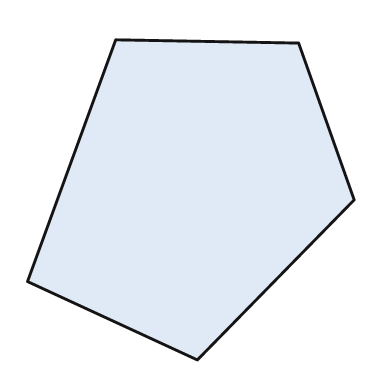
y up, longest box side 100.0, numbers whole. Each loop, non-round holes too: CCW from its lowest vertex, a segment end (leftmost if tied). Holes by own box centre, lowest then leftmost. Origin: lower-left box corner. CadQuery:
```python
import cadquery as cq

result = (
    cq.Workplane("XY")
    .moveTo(52.0, 0.0)
    .lineTo(100.0, 49.0)
    .lineTo(83.0, 97.0)
    .lineTo(27.0, 98.0)
    .lineTo(0.0, 24.0)
    .close()
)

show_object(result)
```